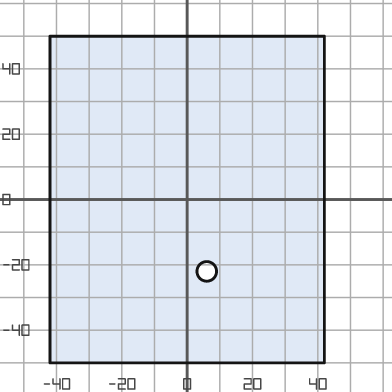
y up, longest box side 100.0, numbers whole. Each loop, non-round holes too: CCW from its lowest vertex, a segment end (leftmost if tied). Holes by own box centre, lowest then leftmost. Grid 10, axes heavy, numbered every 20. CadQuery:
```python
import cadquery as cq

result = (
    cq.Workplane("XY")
    .moveTo(-42.0, -50.0)
    .lineTo(42.0, -50.0)
    .lineTo(42.0, 50.0)
    .lineTo(-42.0, 50.0)
    .close()
    .moveTo(6.0, -22.0)
    .circle(3.0)
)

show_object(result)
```